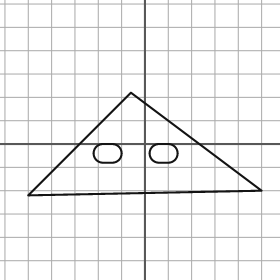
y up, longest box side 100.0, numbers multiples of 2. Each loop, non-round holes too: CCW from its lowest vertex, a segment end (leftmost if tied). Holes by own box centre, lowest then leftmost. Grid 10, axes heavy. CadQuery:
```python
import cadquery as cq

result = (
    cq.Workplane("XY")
    .moveTo(-50.0, -22.0)
    .lineTo(50.0, -20.0)
    .lineTo(-6.0, 22.0)
    .close()
    .moveTo(-18.0, -8.0)
    .lineTo(-14.0, -8.0)
    .threePointArc((-10.0, -4.0), (-14.0, 0.0))
    .lineTo(-18.0, 0.0)
    .threePointArc((-22.0, -4.0), (-18.0, -8.0))
    .close()
    .moveTo(6.0, -8.0)
    .lineTo(10.0, -8.0)
    .threePointArc((14.0, -4.0), (10.0, 0.0))
    .lineTo(6.0, 0.0)
    .threePointArc((2.0, -4.0), (6.0, -8.0))
    .close()
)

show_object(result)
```